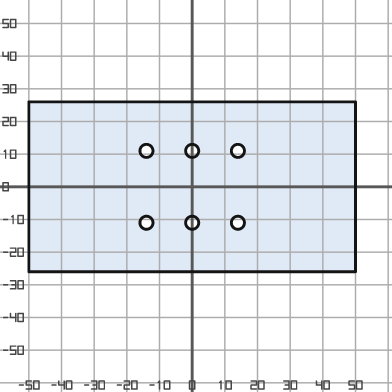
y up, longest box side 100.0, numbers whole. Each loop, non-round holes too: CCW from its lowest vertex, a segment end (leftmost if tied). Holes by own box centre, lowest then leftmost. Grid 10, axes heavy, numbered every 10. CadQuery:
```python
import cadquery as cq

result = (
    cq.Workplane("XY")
    .moveTo(-50.0, -26.0)
    .lineTo(50.0, -26.0)
    .lineTo(50.0, 26.0)
    .lineTo(-50.0, 26.0)
    .close()
    .moveTo(-14.0, -11.0)
    .circle(2.0)
    .moveTo(0.0, -11.0)
    .circle(2.0)
    .moveTo(14.0, -11.0)
    .circle(2.0)
    .moveTo(-14.0, 11.0)
    .circle(2.0)
    .moveTo(0.0, 11.0)
    .circle(2.0)
    .moveTo(14.0, 11.0)
    .circle(2.0)
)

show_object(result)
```